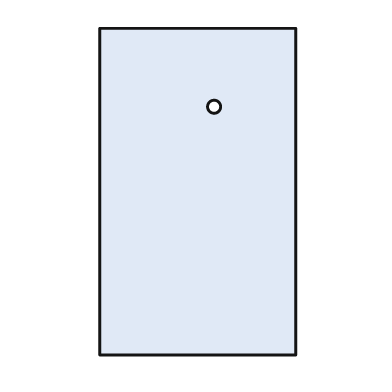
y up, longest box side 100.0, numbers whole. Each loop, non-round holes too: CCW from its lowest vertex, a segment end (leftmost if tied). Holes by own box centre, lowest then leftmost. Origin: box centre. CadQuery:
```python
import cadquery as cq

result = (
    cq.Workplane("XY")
    .moveTo(-30.0, -50.0)
    .lineTo(30.0, -50.0)
    .lineTo(30.0, 50.0)
    .lineTo(-30.0, 50.0)
    .close()
    .moveTo(5.0, 26.0)
    .circle(2.0)
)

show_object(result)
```